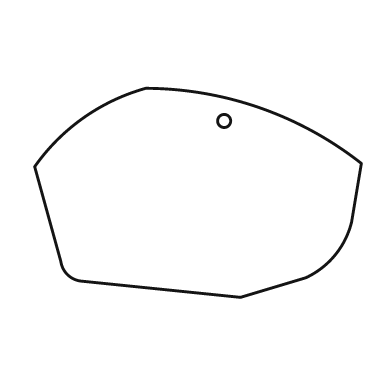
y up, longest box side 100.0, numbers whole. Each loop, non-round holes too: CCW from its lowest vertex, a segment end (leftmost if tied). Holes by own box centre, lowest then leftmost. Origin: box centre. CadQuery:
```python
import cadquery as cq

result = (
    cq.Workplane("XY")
    .moveTo(13.0, -32.0)
    .lineTo(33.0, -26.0)
    .threePointArc((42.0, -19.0), (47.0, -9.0))
    .lineTo(50.0, 9.0)
    .threePointArc((19.0, 26.0), (-16.0, 32.0))
    .threePointArc((-35.0, 23.0), (-50.0, 8.0))
    .lineTo(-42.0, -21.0)
    .threePointArc((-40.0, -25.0), (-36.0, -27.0))
    .close()
    .moveTo(8.0, 22.0)
    .circle(2.0)
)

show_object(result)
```